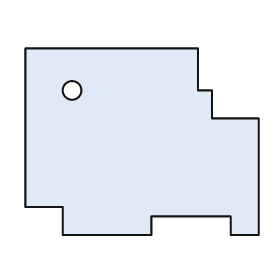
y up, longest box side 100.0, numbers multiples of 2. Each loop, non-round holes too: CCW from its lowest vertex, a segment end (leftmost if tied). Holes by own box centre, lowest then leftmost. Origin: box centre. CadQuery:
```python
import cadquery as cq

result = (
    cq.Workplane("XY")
    .moveTo(-34.0, -40.0)
    .lineTo(4.0, -40.0)
    .lineTo(4.0, -32.0)
    .lineTo(38.0, -32.0)
    .lineTo(38.0, -40.0)
    .lineTo(50.0, -40.0)
    .lineTo(50.0, 10.0)
    .lineTo(30.0, 10.0)
    .lineTo(30.0, 22.0)
    .lineTo(24.0, 22.0)
    .lineTo(24.0, 40.0)
    .lineTo(-50.0, 40.0)
    .lineTo(-50.0, -28.0)
    .lineTo(-34.0, -28.0)
    .close()
    .moveTo(-30.0, 22.0)
    .circle(4.0)
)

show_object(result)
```